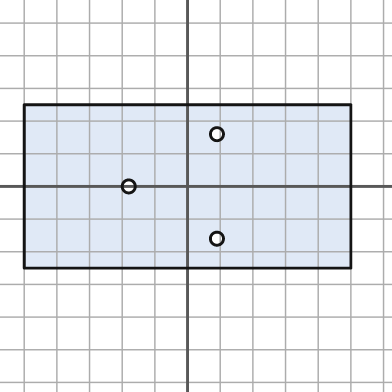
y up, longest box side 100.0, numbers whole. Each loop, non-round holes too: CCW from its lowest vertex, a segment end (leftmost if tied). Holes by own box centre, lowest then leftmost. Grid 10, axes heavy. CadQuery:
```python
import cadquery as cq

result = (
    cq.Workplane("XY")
    .moveTo(-50.0, -25.0)
    .lineTo(50.0, -25.0)
    .lineTo(50.0, 25.0)
    .lineTo(-50.0, 25.0)
    .close()
    .moveTo(9.0, -16.0)
    .circle(2.0)
    .moveTo(-18.0, 0.0)
    .circle(2.0)
    .moveTo(9.0, 16.0)
    .circle(2.0)
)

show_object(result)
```